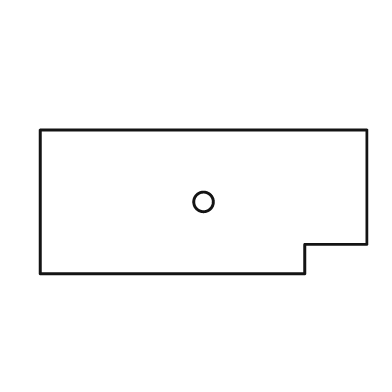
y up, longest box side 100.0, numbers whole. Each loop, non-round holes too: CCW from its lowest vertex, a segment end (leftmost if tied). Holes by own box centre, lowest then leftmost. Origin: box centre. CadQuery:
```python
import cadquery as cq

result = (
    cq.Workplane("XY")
    .moveTo(-50.0, -22.0)
    .lineTo(31.0, -22.0)
    .lineTo(31.0, -13.0)
    .lineTo(50.0, -13.0)
    .lineTo(50.0, 22.0)
    .lineTo(-50.0, 22.0)
    .close()
    .moveTo(0.0, 0.0)
    .circle(3.0)
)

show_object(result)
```